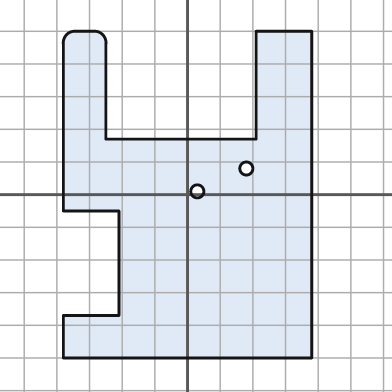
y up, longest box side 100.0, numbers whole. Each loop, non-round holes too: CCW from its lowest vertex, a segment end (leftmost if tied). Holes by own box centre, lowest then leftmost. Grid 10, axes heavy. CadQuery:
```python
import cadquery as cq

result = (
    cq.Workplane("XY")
    .moveTo(-38.0, -50.0)
    .lineTo(38.0, -50.0)
    .lineTo(38.0, 50.0)
    .lineTo(21.0, 50.0)
    .lineTo(21.0, 17.0)
    .lineTo(-25.0, 17.0)
    .lineTo(-25.0, 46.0)
    .threePointArc((-26.0, 49.0), (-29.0, 50.0))
    .lineTo(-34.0, 50.0)
    .threePointArc((-37.0, 49.0), (-38.0, 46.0))
    .lineTo(-38.0, -5.0)
    .lineTo(-21.0, -5.0)
    .lineTo(-21.0, -37.0)
    .lineTo(-38.0, -37.0)
    .close()
    .moveTo(3.0, 1.0)
    .circle(2.0)
    .moveTo(18.0, 8.0)
    .circle(2.0)
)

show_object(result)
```